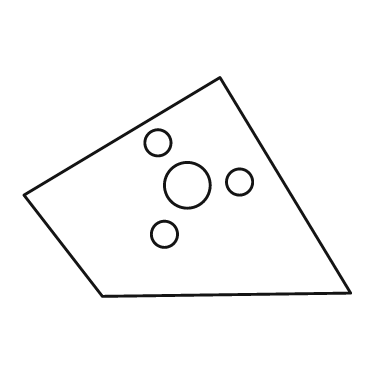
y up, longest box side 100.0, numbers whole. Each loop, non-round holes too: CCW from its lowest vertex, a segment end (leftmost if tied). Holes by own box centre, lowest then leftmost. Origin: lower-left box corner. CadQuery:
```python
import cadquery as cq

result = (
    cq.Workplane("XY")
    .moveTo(24.0, 0.0)
    .lineTo(100.0, 1.0)
    .lineTo(60.0, 67.0)
    .lineTo(0.0, 31.0)
    .close()
    .moveTo(43.0, 19.0)
    .circle(4.0)
    .moveTo(50.0, 34.0)
    .circle(7.0)
    .moveTo(66.0, 35.0)
    .circle(4.0)
    .moveTo(41.0, 47.0)
    .circle(4.0)
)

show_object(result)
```